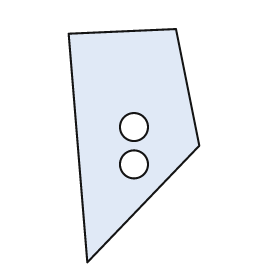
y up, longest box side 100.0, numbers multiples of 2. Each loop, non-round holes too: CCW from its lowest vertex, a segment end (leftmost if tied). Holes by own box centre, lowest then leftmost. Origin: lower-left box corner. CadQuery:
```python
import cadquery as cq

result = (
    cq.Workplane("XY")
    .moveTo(8.0, 0.0)
    .lineTo(56.0, 50.0)
    .lineTo(46.0, 100.0)
    .lineTo(0.0, 98.0)
    .close()
    .moveTo(28.0, 42.0)
    .circle(6.0)
    .moveTo(28.0, 58.0)
    .circle(6.0)
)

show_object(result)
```